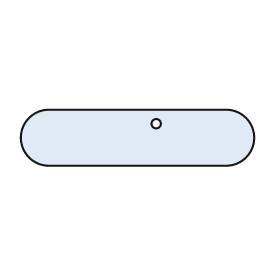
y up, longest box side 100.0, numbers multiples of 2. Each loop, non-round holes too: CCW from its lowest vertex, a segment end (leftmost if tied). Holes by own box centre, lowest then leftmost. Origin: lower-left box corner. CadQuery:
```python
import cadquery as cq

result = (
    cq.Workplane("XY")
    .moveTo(12.0, 0.0)
    .lineTo(88.0, 0.0)
    .threePointArc((100.0, 12.0), (88.0, 24.0))
    .lineTo(12.0, 24.0)
    .threePointArc((0.0, 12.0), (12.0, 0.0))
    .close()
    .moveTo(58.0, 18.0)
    .circle(2.0)
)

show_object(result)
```